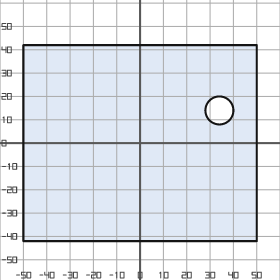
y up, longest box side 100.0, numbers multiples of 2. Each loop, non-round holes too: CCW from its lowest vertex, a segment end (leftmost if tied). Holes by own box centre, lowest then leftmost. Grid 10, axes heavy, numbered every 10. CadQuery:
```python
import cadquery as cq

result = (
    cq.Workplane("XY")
    .moveTo(-50.0, -42.0)
    .lineTo(50.0, -42.0)
    .lineTo(50.0, 42.0)
    .lineTo(-50.0, 42.0)
    .close()
    .moveTo(34.0, 14.0)
    .circle(6.0)
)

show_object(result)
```